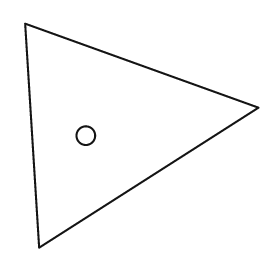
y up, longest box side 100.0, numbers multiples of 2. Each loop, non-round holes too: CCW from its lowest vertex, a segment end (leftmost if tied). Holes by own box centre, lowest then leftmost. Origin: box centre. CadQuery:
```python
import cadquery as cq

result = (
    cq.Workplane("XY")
    .moveTo(-44.0, -48.0)
    .lineTo(50.0, 12.0)
    .lineTo(-50.0, 48.0)
    .close()
    .moveTo(-24.0, 0.0)
    .circle(4.0)
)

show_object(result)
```